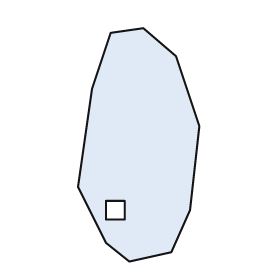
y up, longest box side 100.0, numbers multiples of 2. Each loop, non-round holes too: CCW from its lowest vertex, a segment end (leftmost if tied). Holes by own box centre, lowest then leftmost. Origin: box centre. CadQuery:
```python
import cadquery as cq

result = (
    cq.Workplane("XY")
    .moveTo(-4.0, -50.0)
    .lineTo(14.0, -46.0)
    .lineTo(22.0, -28.0)
    .lineTo(26.0, 8.0)
    .lineTo(16.0, 38.0)
    .lineTo(2.0, 50.0)
    .lineTo(-12.0, 48.0)
    .lineTo(-20.0, 24.0)
    .lineTo(-26.0, -18.0)
    .lineTo(-14.0, -42.0)
    .close()
    .moveTo(-14.0, -32.0)
    .lineTo(-6.0, -32.0)
    .lineTo(-6.0, -24.0)
    .lineTo(-14.0, -24.0)
    .close()
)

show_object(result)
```